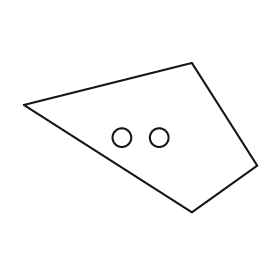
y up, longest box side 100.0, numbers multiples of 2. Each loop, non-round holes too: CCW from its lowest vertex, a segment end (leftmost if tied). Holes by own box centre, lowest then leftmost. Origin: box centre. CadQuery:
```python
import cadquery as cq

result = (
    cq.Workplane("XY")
    .moveTo(22.0, -32.0)
    .lineTo(50.0, -12.0)
    .lineTo(22.0, 32.0)
    .lineTo(-50.0, 14.0)
    .close()
    .moveTo(-8.0, 0.0)
    .circle(4.0)
    .moveTo(8.0, 0.0)
    .circle(4.0)
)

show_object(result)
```